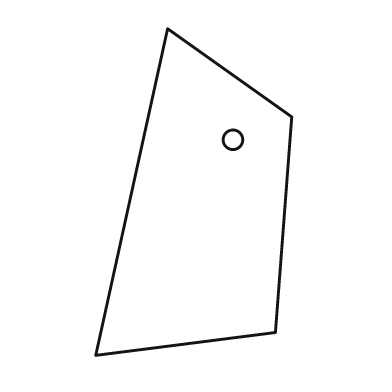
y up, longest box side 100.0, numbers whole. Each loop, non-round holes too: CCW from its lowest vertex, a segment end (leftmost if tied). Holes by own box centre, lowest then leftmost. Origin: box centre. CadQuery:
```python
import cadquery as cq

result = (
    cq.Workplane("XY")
    .moveTo(-30.0, -50.0)
    .lineTo(25.0, -43.0)
    .lineTo(30.0, 23.0)
    .lineTo(-8.0, 50.0)
    .close()
    .moveTo(12.0, 16.0)
    .circle(3.0)
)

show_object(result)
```